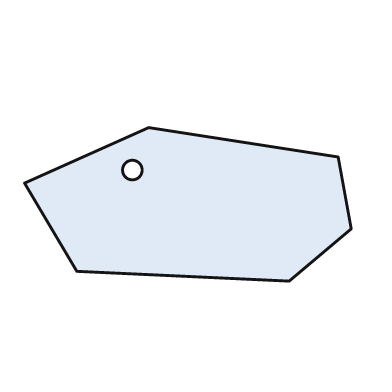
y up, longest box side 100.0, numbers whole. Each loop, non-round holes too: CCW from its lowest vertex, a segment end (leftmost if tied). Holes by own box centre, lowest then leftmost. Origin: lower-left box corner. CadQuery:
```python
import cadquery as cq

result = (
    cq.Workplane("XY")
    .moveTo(81.0, 0.0)
    .lineTo(100.0, 16.0)
    .lineTo(96.0, 38.0)
    .lineTo(38.0, 47.0)
    .lineTo(0.0, 30.0)
    .lineTo(16.0, 3.0)
    .close()
    .moveTo(33.0, 34.0)
    .circle(3.0)
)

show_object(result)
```